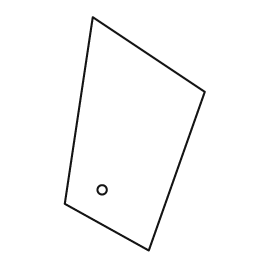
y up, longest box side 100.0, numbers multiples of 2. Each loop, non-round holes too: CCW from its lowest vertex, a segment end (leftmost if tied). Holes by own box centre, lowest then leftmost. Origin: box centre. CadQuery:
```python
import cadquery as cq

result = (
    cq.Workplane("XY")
    .moveTo(6.0, -50.0)
    .lineTo(30.0, 18.0)
    .lineTo(-18.0, 50.0)
    .lineTo(-30.0, -30.0)
    .close()
    .moveTo(-14.0, -24.0)
    .circle(2.0)
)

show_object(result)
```